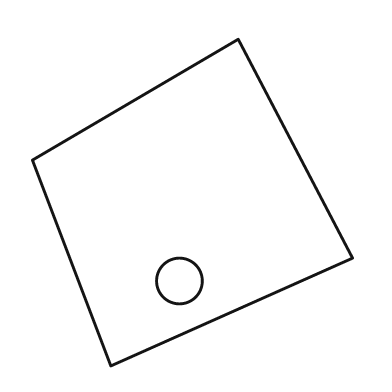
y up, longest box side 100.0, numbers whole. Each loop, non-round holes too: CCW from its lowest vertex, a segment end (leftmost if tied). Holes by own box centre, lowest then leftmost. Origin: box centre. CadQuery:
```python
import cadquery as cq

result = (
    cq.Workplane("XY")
    .moveTo(-25.0, -50.0)
    .lineTo(49.0, -17.0)
    .lineTo(14.0, 50.0)
    .lineTo(-49.0, 13.0)
    .close()
    .moveTo(-4.0, -24.0)
    .circle(7.0)
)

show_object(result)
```